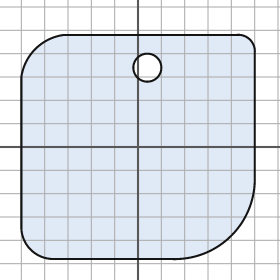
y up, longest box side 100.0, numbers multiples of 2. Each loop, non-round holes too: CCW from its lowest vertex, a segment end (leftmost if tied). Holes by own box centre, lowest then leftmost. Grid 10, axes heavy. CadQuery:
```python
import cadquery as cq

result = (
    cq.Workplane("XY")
    .moveTo(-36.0, -48.0)
    .lineTo(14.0, -48.0)
    .threePointArc((40.0, -38.0), (50.0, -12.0))
    .lineTo(50.0, 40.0)
    .threePointArc((48.0, 46.0), (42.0, 48.0))
    .lineTo(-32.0, 48.0)
    .threePointArc((-44.0, 42.0), (-50.0, 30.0))
    .lineTo(-50.0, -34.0)
    .threePointArc((-46.0, -44.0), (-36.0, -48.0))
    .close()
    .moveTo(4.0, 34.0)
    .circle(6.0)
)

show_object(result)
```